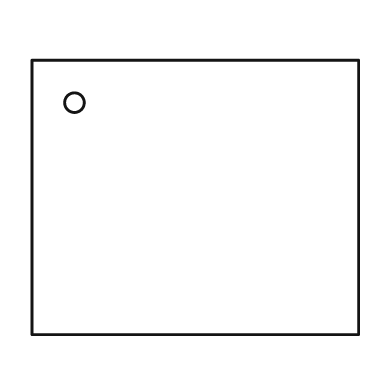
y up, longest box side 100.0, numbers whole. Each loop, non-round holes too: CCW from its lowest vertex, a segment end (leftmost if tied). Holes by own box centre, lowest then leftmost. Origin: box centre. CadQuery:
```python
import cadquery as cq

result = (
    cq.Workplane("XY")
    .moveTo(-50.0, -42.0)
    .lineTo(50.0, -42.0)
    .lineTo(50.0, 42.0)
    .lineTo(-50.0, 42.0)
    .close()
    .moveTo(-37.0, 29.0)
    .circle(3.0)
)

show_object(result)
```